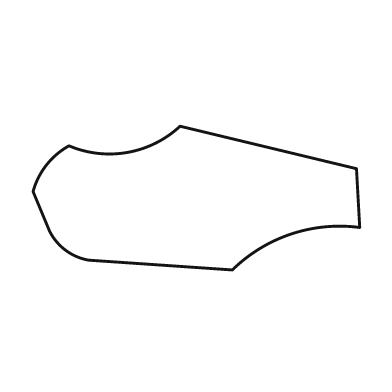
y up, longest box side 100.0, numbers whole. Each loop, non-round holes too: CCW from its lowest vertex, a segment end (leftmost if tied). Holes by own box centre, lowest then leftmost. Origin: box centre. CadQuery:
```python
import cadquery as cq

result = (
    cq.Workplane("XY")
    .moveTo(11.0, -22.0)
    .threePointArc((29.0, -11.0), (50.0, -9.0))
    .lineTo(49.0, 9.0)
    .lineTo(-5.0, 22.0)
    .threePointArc((-21.0, 14.0), (-39.0, 16.0))
    .threePointArc((-46.0, 10.0), (-50.0, 2.0))
    .lineTo(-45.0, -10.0)
    .threePointArc((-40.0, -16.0), (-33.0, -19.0))
    .close()
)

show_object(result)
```